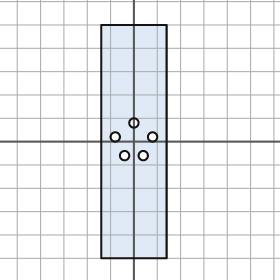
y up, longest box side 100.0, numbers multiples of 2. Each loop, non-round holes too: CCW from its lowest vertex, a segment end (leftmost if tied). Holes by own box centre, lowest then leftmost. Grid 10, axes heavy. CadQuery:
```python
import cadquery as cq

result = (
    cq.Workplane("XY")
    .moveTo(-14.0, -50.0)
    .lineTo(14.0, -50.0)
    .lineTo(14.0, 50.0)
    .lineTo(-14.0, 50.0)
    .close()
    .moveTo(-4.0, -6.0)
    .circle(2.0)
    .moveTo(4.0, -6.0)
    .circle(2.0)
    .moveTo(-8.0, 2.0)
    .circle(2.0)
    .moveTo(8.0, 2.0)
    .circle(2.0)
    .moveTo(0.0, 8.0)
    .circle(2.0)
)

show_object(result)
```